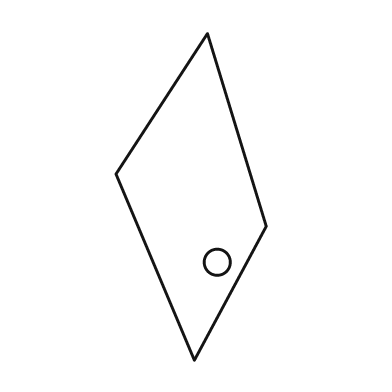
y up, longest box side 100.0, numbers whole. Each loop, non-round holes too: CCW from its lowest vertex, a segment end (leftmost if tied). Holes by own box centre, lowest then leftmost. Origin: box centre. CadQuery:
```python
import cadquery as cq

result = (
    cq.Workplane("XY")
    .moveTo(1.0, -50.0)
    .lineTo(23.0, -9.0)
    .lineTo(5.0, 50.0)
    .lineTo(-23.0, 7.0)
    .close()
    .moveTo(8.0, -20.0)
    .circle(4.0)
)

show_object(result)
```